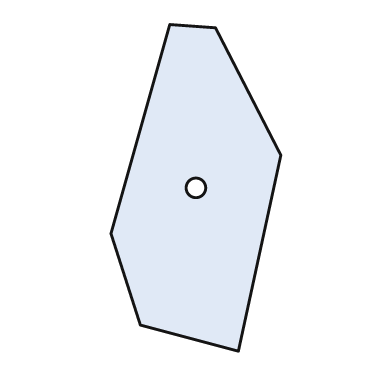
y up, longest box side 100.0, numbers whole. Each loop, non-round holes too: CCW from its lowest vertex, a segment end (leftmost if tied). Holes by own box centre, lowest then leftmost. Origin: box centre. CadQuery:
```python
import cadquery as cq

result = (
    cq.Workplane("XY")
    .moveTo(13.0, -50.0)
    .lineTo(26.0, 10.0)
    .lineTo(6.0, 49.0)
    .lineTo(-8.0, 50.0)
    .lineTo(-26.0, -14.0)
    .lineTo(-17.0, -42.0)
    .close()
    .moveTo(0.0, 0.0)
    .circle(3.0)
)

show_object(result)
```